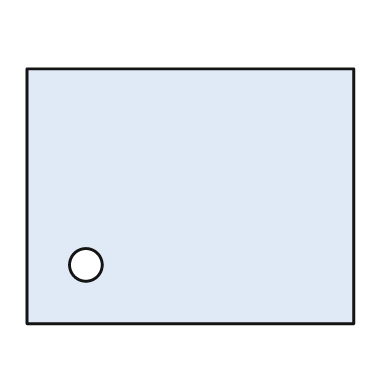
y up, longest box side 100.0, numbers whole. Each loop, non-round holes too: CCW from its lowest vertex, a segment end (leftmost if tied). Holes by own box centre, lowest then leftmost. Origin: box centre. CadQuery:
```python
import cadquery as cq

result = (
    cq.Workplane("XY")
    .moveTo(-50.0, -39.0)
    .lineTo(50.0, -39.0)
    .lineTo(50.0, 39.0)
    .lineTo(-50.0, 39.0)
    .close()
    .moveTo(-32.0, -21.0)
    .circle(5.0)
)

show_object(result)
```